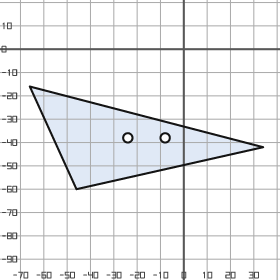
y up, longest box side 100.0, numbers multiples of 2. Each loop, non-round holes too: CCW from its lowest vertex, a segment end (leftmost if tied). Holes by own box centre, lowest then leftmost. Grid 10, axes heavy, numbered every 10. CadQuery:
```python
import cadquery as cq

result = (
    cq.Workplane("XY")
    .moveTo(-46.0, -60.0)
    .lineTo(34.0, -42.0)
    .lineTo(-66.0, -16.0)
    .close()
    .moveTo(-24.0, -38.0)
    .circle(2.0)
    .moveTo(-8.0, -38.0)
    .circle(2.0)
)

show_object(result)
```